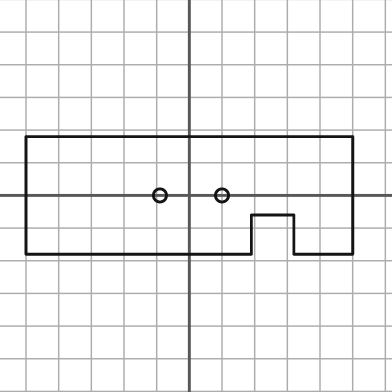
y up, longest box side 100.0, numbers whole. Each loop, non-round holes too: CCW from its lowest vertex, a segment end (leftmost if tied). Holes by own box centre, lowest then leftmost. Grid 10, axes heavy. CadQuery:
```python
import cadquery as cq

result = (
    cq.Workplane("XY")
    .moveTo(-50.0, -18.0)
    .lineTo(19.0, -18.0)
    .lineTo(19.0, -6.0)
    .lineTo(32.0, -6.0)
    .lineTo(32.0, -18.0)
    .lineTo(50.0, -18.0)
    .lineTo(50.0, 18.0)
    .lineTo(-50.0, 18.0)
    .close()
    .moveTo(-9.0, 0.0)
    .circle(2.0)
    .moveTo(10.0, 0.0)
    .circle(2.0)
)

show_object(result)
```